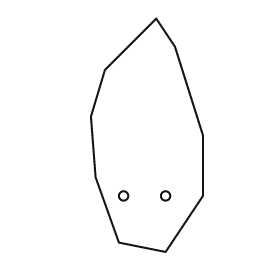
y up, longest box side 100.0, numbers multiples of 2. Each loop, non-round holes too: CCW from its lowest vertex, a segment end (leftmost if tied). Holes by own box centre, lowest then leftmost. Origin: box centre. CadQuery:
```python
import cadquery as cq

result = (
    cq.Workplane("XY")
    .moveTo(8.0, -50.0)
    .lineTo(24.0, -26.0)
    .lineTo(24.0, 0.0)
    .lineTo(12.0, 38.0)
    .lineTo(4.0, 50.0)
    .lineTo(-18.0, 28.0)
    .lineTo(-24.0, 8.0)
    .lineTo(-22.0, -18.0)
    .lineTo(-12.0, -46.0)
    .close()
    .moveTo(-10.0, -26.0)
    .circle(2.0)
    .moveTo(8.0, -26.0)
    .circle(2.0)
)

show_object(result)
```